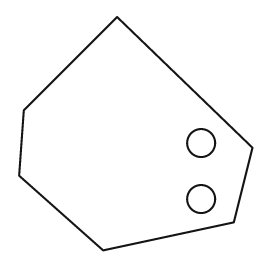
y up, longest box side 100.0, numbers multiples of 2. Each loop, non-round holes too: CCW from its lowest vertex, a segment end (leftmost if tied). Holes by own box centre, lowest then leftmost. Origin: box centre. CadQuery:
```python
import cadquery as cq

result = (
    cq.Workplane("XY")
    .moveTo(-14.0, -50.0)
    .lineTo(42.0, -38.0)
    .lineTo(50.0, -6.0)
    .lineTo(-8.0, 50.0)
    .lineTo(-48.0, 10.0)
    .lineTo(-50.0, -18.0)
    .close()
    .moveTo(28.0, -28.0)
    .circle(6.0)
    .moveTo(28.0, -4.0)
    .circle(6.0)
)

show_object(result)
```